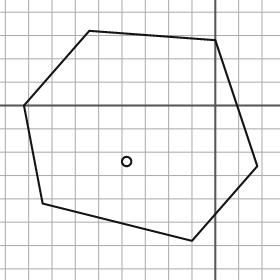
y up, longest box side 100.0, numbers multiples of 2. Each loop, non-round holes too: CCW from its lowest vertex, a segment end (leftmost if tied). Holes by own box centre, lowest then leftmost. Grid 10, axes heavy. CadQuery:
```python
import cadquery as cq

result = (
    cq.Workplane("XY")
    .moveTo(-10.0, -58.0)
    .lineTo(18.0, -26.0)
    .lineTo(0.0, 28.0)
    .lineTo(-54.0, 32.0)
    .lineTo(-82.0, 0.0)
    .lineTo(-74.0, -42.0)
    .close()
    .moveTo(-38.0, -24.0)
    .circle(2.0)
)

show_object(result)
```